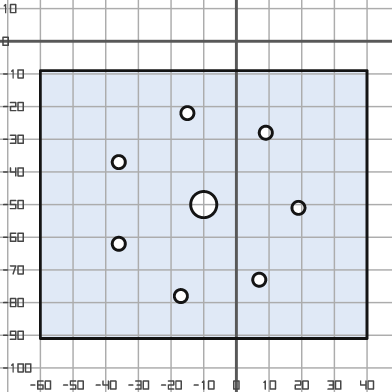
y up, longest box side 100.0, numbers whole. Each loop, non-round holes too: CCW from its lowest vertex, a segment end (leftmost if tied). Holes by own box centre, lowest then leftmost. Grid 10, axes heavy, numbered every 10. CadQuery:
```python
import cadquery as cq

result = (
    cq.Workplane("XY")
    .moveTo(-60.0, -91.0)
    .lineTo(40.0, -91.0)
    .lineTo(40.0, -9.0)
    .lineTo(-60.0, -9.0)
    .close()
    .moveTo(-17.0, -78.0)
    .circle(2.0)
    .moveTo(7.0, -73.0)
    .circle(2.0)
    .moveTo(-36.0, -62.0)
    .circle(2.0)
    .moveTo(19.0, -51.0)
    .circle(2.0)
    .moveTo(-10.0, -50.0)
    .circle(4.0)
    .moveTo(-36.0, -37.0)
    .circle(2.0)
    .moveTo(9.0, -28.0)
    .circle(2.0)
    .moveTo(-15.0, -22.0)
    .circle(2.0)
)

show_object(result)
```